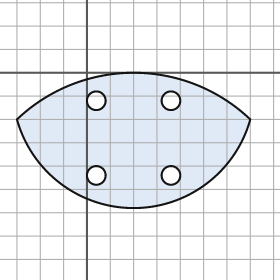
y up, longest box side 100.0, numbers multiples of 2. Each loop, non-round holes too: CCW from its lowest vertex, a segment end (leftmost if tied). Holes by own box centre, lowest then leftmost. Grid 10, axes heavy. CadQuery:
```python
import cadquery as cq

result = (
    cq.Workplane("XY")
    .moveTo(-30.0, -20.0)
    .threePointArc((20.0, -58.0), (70.0, -20.0))
    .threePointArc((20.0, 0.0), (-30.0, -20.0))
    .close()
    .moveTo(4.0, -44.0)
    .circle(4.0)
    .moveTo(36.0, -44.0)
    .circle(4.0)
    .moveTo(4.0, -12.0)
    .circle(4.0)
    .moveTo(36.0, -12.0)
    .circle(4.0)
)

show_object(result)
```